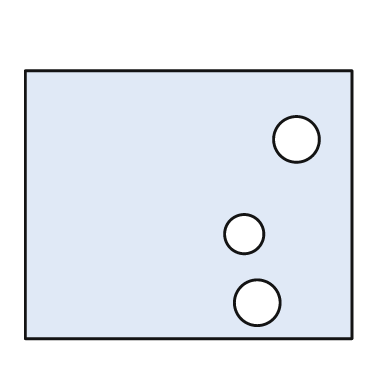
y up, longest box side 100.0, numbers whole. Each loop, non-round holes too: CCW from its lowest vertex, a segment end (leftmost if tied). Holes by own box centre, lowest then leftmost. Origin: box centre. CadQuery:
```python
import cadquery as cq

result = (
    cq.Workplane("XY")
    .moveTo(-50.0, -41.0)
    .lineTo(50.0, -41.0)
    .lineTo(50.0, 41.0)
    .lineTo(-50.0, 41.0)
    .close()
    .moveTo(21.0, -30.0)
    .circle(7.0)
    .moveTo(17.0, -9.0)
    .circle(6.0)
    .moveTo(33.0, 20.0)
    .circle(7.0)
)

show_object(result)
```